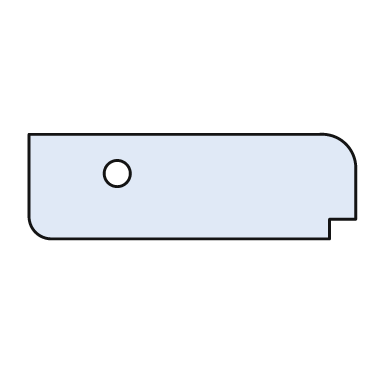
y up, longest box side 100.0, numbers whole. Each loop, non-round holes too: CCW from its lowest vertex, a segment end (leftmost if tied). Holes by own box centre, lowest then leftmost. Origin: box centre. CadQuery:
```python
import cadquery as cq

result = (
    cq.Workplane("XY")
    .moveTo(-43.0, -16.0)
    .lineTo(42.0, -16.0)
    .lineTo(42.0, -10.0)
    .lineTo(50.0, -10.0)
    .lineTo(50.0, 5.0)
    .threePointArc((47.0, 13.0), (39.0, 16.0))
    .lineTo(-50.0, 16.0)
    .lineTo(-50.0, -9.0)
    .threePointArc((-48.0, -14.0), (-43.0, -16.0))
    .close()
    .moveTo(-23.0, 4.0)
    .circle(4.0)
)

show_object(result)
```